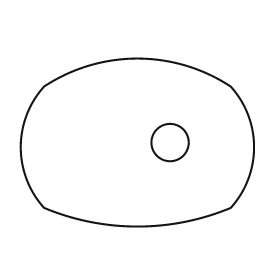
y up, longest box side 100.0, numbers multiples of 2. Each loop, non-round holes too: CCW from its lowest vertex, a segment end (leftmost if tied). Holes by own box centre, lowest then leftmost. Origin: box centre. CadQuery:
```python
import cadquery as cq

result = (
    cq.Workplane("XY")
    .moveTo(-40.0, -28.0)
    .threePointArc((0.0, -36.0), (40.0, -28.0))
    .threePointArc((50.0, -2.0), (40.0, 24.0))
    .threePointArc((0.0, 36.0), (-40.0, 24.0))
    .threePointArc((-50.0, -2.0), (-40.0, -28.0))
    .close()
    .moveTo(14.0, 0.0)
    .circle(8.0)
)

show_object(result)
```